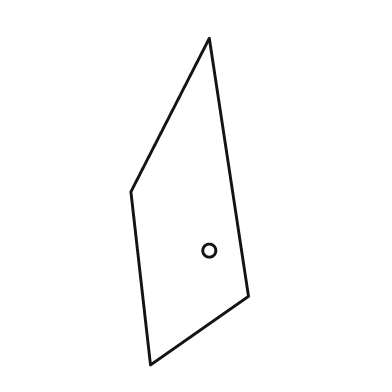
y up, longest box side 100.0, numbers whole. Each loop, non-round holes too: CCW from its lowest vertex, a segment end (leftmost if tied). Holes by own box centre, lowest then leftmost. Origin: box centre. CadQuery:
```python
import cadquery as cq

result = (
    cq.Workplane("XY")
    .moveTo(-12.0, -50.0)
    .lineTo(18.0, -29.0)
    .lineTo(6.0, 50.0)
    .lineTo(-18.0, 3.0)
    .close()
    .moveTo(6.0, -15.0)
    .circle(2.0)
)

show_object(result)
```